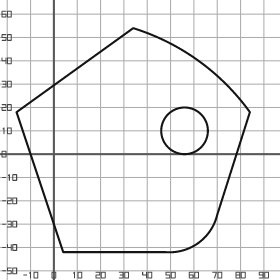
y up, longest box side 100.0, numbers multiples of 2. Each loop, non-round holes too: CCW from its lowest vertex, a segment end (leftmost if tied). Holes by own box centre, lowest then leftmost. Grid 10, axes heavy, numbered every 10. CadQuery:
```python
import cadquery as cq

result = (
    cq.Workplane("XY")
    .moveTo(4.0, -42.0)
    .lineTo(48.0, -42.0)
    .threePointArc((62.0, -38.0), (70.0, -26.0))
    .lineTo(84.0, 18.0)
    .threePointArc((62.0, 40.0), (34.0, 54.0))
    .lineTo(-16.0, 18.0)
    .close()
    .moveTo(56.0, 10.0)
    .circle(10.0)
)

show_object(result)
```